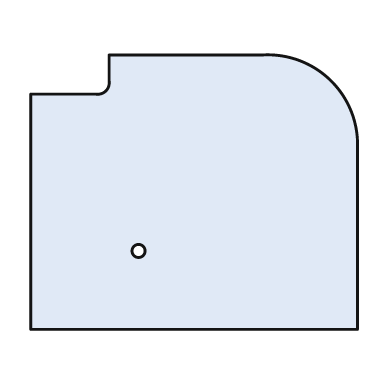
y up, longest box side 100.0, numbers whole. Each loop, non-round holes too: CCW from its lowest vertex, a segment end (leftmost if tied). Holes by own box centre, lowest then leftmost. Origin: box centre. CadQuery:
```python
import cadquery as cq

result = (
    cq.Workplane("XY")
    .moveTo(-50.0, -42.0)
    .lineTo(50.0, -42.0)
    .lineTo(50.0, 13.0)
    .threePointArc((42.0, 34.0), (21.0, 42.0))
    .lineTo(-26.0, 42.0)
    .lineTo(-26.0, 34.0)
    .threePointArc((-27.0, 31.0), (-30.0, 30.0))
    .lineTo(-50.0, 30.0)
    .close()
    .moveTo(-17.0, -18.0)
    .circle(2.0)
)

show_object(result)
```